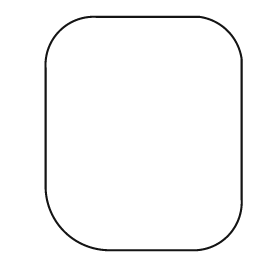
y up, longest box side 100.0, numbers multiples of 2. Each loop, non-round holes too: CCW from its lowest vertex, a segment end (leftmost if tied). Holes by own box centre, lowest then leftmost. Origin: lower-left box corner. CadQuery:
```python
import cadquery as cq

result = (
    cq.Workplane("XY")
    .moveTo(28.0, 0.0)
    .lineTo(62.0, 0.0)
    .threePointArc((78.0, 6.0), (84.0, 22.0))
    .lineTo(84.0, 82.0)
    .threePointArc((78.0, 94.0), (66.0, 100.0))
    .lineTo(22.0, 100.0)
    .threePointArc((6.0, 94.0), (0.0, 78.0))
    .lineTo(0.0, 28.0)
    .threePointArc((8.0, 8.0), (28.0, 0.0))
    .close()
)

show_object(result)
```